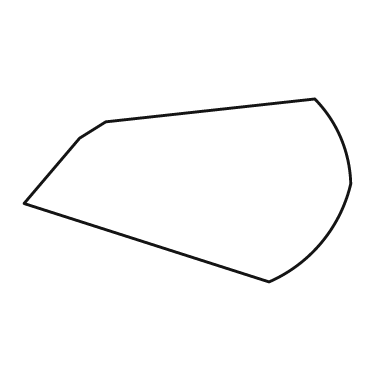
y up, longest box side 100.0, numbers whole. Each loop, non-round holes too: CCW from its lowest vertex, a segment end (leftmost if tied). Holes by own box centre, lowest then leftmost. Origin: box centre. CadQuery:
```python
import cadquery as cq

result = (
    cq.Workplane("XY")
    .moveTo(25.0, -28.0)
    .threePointArc((41.0, -16.0), (50.0, 2.0))
    .threePointArc((47.0, 16.0), (39.0, 28.0))
    .lineTo(-25.0, 21.0)
    .lineTo(-33.0, 16.0)
    .lineTo(-50.0, -4.0)
    .close()
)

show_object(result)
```